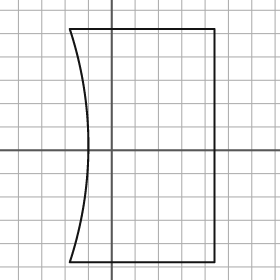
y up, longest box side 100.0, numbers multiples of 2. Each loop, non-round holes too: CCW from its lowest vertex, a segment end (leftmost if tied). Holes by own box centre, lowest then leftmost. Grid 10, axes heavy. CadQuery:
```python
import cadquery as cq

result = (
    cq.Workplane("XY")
    .moveTo(-18.0, -48.0)
    .lineTo(44.0, -48.0)
    .lineTo(44.0, 52.0)
    .lineTo(-18.0, 52.0)
    .threePointArc((-10.0, 2.0), (-18.0, -48.0))
    .close()
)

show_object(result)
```